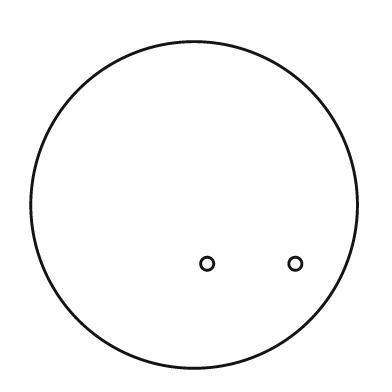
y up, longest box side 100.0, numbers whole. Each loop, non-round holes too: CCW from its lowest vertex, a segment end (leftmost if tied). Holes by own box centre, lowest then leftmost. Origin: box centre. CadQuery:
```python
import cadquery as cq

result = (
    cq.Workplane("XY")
    .moveTo(0.0, 0.0)
    .circle(50.0)
    .moveTo(4.0, -18.0)
    .circle(2.0)
    .moveTo(31.0, -18.0)
    .circle(2.0)
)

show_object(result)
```